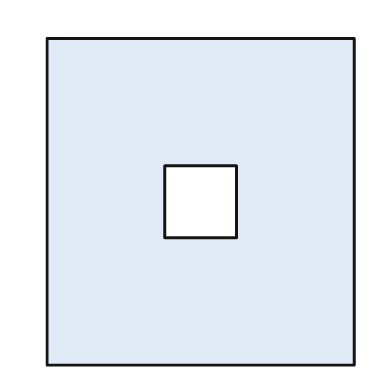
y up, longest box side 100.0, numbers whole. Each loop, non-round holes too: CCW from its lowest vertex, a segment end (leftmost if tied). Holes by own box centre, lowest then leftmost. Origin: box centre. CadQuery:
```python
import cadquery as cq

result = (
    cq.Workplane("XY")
    .moveTo(-47.0, -50.0)
    .lineTo(47.0, -50.0)
    .lineTo(47.0, 50.0)
    .lineTo(-47.0, 50.0)
    .close()
    .moveTo(-11.0, -11.0)
    .lineTo(11.0, -11.0)
    .lineTo(11.0, 11.0)
    .lineTo(-11.0, 11.0)
    .close()
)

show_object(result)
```